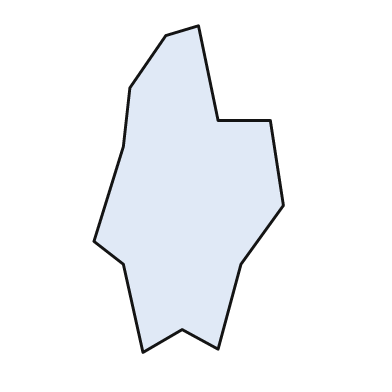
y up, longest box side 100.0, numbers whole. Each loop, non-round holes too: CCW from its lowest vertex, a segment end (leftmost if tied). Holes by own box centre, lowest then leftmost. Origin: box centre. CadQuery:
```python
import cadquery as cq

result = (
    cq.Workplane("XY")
    .moveTo(-14.0, -50.0)
    .lineTo(-2.0, -43.0)
    .lineTo(9.0, -49.0)
    .lineTo(16.0, -23.0)
    .lineTo(29.0, -5.0)
    .lineTo(25.0, 21.0)
    .lineTo(9.0, 21.0)
    .lineTo(3.0, 50.0)
    .lineTo(-7.0, 47.0)
    .lineTo(-18.0, 31.0)
    .lineTo(-20.0, 13.0)
    .lineTo(-29.0, -16.0)
    .lineTo(-20.0, -23.0)
    .close()
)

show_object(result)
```